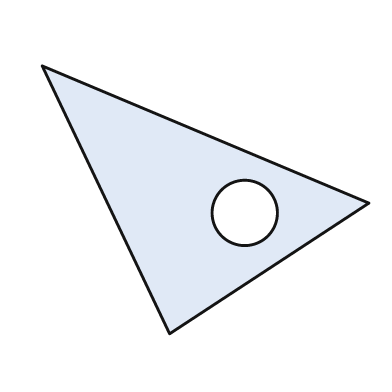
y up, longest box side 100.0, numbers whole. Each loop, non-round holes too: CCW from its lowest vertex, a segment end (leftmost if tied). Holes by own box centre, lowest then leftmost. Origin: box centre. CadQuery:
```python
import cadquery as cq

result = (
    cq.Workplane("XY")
    .moveTo(-11.0, -41.0)
    .lineTo(50.0, -1.0)
    .lineTo(-50.0, 41.0)
    .close()
    .moveTo(12.0, -4.0)
    .circle(10.0)
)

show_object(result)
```